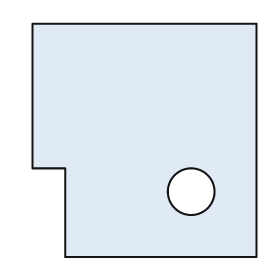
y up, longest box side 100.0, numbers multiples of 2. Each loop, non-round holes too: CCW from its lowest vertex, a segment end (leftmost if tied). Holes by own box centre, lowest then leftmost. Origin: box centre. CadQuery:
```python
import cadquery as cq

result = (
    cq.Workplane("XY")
    .moveTo(-34.0, -50.0)
    .lineTo(48.0, -50.0)
    .lineTo(48.0, 50.0)
    .lineTo(-48.0, 50.0)
    .lineTo(-48.0, -12.0)
    .lineTo(-34.0, -12.0)
    .close()
    .moveTo(20.0, -22.0)
    .circle(10.0)
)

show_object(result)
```